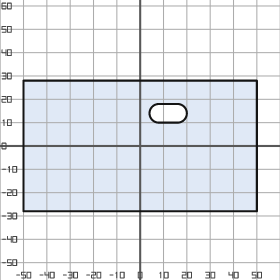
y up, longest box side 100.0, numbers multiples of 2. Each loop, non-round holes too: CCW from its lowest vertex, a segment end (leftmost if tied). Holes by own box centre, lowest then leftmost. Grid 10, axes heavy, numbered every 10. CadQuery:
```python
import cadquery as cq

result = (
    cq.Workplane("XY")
    .moveTo(-50.0, -28.0)
    .lineTo(50.0, -28.0)
    .lineTo(50.0, 28.0)
    .lineTo(-50.0, 28.0)
    .close()
    .moveTo(8.0, 10.0)
    .lineTo(16.0, 10.0)
    .threePointArc((20.0, 14.0), (16.0, 18.0))
    .lineTo(8.0, 18.0)
    .threePointArc((4.0, 14.0), (8.0, 10.0))
    .close()
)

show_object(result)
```